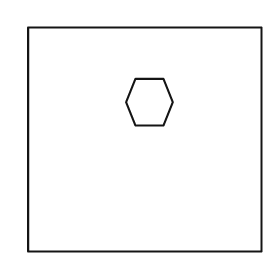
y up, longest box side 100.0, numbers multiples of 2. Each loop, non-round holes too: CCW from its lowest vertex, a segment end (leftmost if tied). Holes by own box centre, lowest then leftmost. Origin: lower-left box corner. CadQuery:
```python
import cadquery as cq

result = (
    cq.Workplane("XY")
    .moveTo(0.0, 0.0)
    .lineTo(100.0, 0.0)
    .lineTo(100.0, 96.0)
    .lineTo(0.0, 96.0)
    .close()
    .moveTo(46.0, 54.0)
    .lineTo(58.0, 54.0)
    .lineTo(62.0, 64.0)
    .lineTo(58.0, 74.0)
    .lineTo(46.0, 74.0)
    .lineTo(42.0, 64.0)
    .close()
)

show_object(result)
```